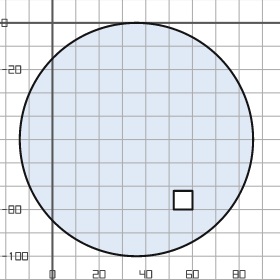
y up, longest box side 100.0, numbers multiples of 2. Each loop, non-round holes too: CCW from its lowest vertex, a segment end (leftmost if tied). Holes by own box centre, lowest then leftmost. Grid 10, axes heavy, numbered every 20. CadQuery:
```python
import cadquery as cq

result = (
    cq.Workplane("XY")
    .moveTo(36.0, -50.0)
    .circle(50.0)
    .moveTo(52.0, -80.0)
    .lineTo(60.0, -80.0)
    .lineTo(60.0, -72.0)
    .lineTo(52.0, -72.0)
    .close()
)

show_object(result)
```